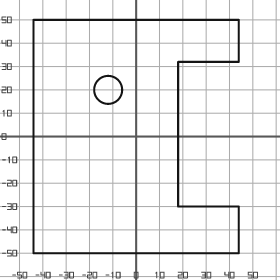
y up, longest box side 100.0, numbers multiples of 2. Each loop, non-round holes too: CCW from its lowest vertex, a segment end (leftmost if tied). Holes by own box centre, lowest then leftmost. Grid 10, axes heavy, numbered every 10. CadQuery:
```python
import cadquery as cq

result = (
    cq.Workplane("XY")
    .moveTo(-44.0, -50.0)
    .lineTo(44.0, -50.0)
    .lineTo(44.0, -30.0)
    .lineTo(18.0, -30.0)
    .lineTo(18.0, 32.0)
    .lineTo(44.0, 32.0)
    .lineTo(44.0, 50.0)
    .lineTo(-44.0, 50.0)
    .close()
    .moveTo(-12.0, 20.0)
    .circle(6.0)
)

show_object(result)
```